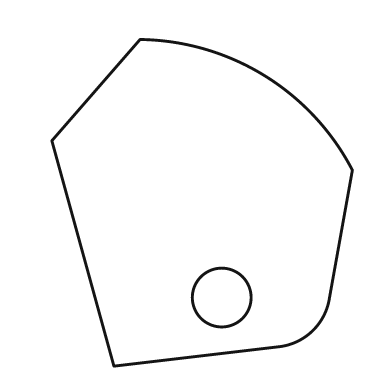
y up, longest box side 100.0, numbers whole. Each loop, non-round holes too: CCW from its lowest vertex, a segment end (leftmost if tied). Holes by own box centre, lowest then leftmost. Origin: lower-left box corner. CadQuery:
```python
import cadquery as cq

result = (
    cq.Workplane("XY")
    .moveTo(19.0, 0.0)
    .lineTo(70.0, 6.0)
    .threePointArc((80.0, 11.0), (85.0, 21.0))
    .lineTo(92.0, 60.0)
    .threePointArc((65.0, 89.0), (27.0, 100.0))
    .lineTo(0.0, 69.0)
    .close()
    .moveTo(52.0, 21.0)
    .circle(9.0)
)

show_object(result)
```